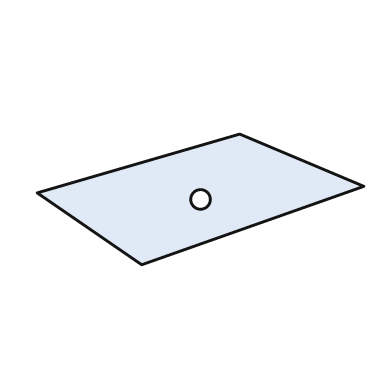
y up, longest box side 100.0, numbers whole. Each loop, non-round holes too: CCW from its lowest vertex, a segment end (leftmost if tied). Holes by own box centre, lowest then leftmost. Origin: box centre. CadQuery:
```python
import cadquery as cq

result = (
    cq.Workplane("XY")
    .moveTo(-18.0, -20.0)
    .lineTo(50.0, 4.0)
    .lineTo(12.0, 20.0)
    .lineTo(-50.0, 2.0)
    .close()
    .moveTo(0.0, 0.0)
    .circle(3.0)
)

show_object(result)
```